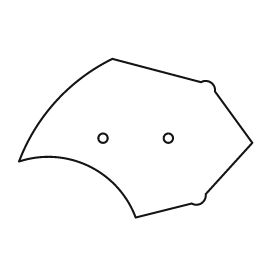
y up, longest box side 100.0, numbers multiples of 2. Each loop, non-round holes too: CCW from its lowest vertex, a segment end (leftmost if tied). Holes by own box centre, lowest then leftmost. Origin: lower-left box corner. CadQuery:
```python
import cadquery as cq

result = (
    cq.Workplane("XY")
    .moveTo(50.0, 0.0)
    .lineTo(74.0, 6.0)
    .threePointArc((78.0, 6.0), (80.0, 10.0))
    .lineTo(100.0, 32.0)
    .lineTo(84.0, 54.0)
    .threePointArc((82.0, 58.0), (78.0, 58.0))
    .lineTo(40.0, 68.0)
    .threePointArc((16.0, 50.0), (0.0, 24.0))
    .threePointArc((30.0, 22.0), (50.0, 0.0))
    .close()
    .moveTo(36.0, 34.0)
    .circle(2.0)
    .moveTo(64.0, 34.0)
    .circle(2.0)
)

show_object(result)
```